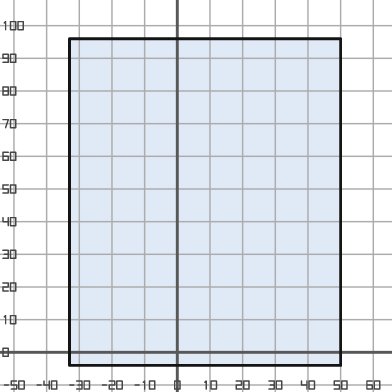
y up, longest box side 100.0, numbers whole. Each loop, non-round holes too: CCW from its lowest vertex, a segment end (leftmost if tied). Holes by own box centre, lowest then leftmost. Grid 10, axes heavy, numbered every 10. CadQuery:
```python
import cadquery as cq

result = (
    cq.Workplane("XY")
    .moveTo(-33.0, -4.0)
    .lineTo(50.0, -4.0)
    .lineTo(50.0, 96.0)
    .lineTo(-33.0, 96.0)
    .close()
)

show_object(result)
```